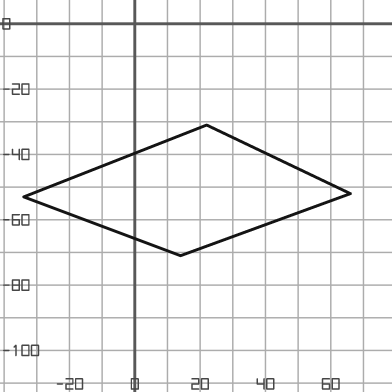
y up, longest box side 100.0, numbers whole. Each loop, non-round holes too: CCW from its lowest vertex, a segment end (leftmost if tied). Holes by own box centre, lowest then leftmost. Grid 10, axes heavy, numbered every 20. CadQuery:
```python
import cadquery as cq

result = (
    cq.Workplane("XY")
    .moveTo(14.0, -71.0)
    .lineTo(66.0, -52.0)
    .lineTo(22.0, -31.0)
    .lineTo(-34.0, -53.0)
    .close()
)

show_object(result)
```